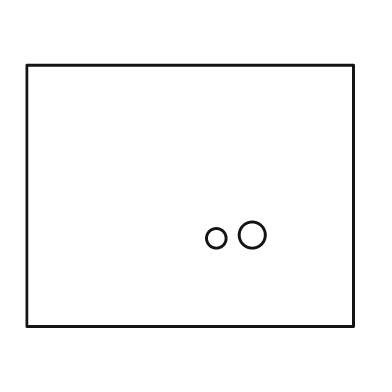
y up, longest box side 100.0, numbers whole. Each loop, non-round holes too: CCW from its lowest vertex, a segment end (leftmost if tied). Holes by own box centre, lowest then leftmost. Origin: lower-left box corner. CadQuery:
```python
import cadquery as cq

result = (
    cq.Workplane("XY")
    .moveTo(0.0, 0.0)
    .lineTo(100.0, 0.0)
    .lineTo(100.0, 80.0)
    .lineTo(0.0, 80.0)
    .close()
    .moveTo(58.0, 27.0)
    .circle(3.0)
    .moveTo(69.0, 28.0)
    .circle(4.0)
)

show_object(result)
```